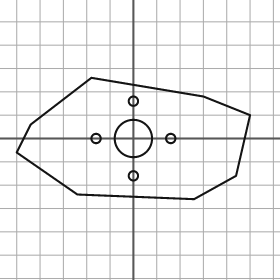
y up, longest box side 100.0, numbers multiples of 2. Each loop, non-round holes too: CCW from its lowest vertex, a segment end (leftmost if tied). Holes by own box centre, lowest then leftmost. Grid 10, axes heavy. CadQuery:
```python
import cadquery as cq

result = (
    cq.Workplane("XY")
    .moveTo(26.0, -26.0)
    .lineTo(44.0, -16.0)
    .lineTo(50.0, 10.0)
    .lineTo(30.0, 18.0)
    .lineTo(-18.0, 26.0)
    .lineTo(-44.0, 6.0)
    .lineTo(-50.0, -6.0)
    .lineTo(-24.0, -24.0)
    .close()
    .moveTo(0.0, -16.0)
    .circle(2.0)
    .moveTo(-16.0, 0.0)
    .circle(2.0)
    .moveTo(0.0, 0.0)
    .circle(8.0)
    .moveTo(16.0, 0.0)
    .circle(2.0)
    .moveTo(0.0, 16.0)
    .circle(2.0)
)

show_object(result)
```